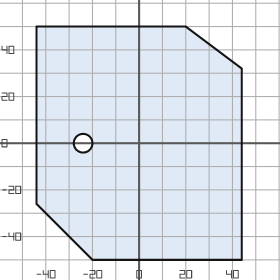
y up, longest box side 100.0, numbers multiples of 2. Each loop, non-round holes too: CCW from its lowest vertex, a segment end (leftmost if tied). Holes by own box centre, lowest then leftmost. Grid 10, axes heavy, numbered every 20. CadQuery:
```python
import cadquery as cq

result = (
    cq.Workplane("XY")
    .moveTo(-20.0, -50.0)
    .lineTo(44.0, -50.0)
    .lineTo(44.0, 32.0)
    .lineTo(20.0, 50.0)
    .lineTo(-44.0, 50.0)
    .lineTo(-44.0, -26.0)
    .close()
    .moveTo(-24.0, 0.0)
    .circle(4.0)
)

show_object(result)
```